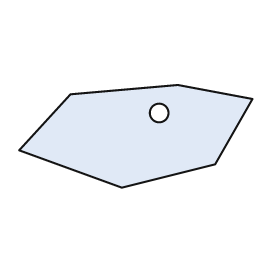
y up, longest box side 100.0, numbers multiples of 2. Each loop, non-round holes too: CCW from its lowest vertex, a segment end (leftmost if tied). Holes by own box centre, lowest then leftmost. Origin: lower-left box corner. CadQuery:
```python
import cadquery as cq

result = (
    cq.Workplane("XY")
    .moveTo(44.0, 0.0)
    .lineTo(84.0, 10.0)
    .lineTo(100.0, 38.0)
    .lineTo(68.0, 44.0)
    .lineTo(22.0, 40.0)
    .lineTo(0.0, 16.0)
    .close()
    .moveTo(60.0, 32.0)
    .circle(4.0)
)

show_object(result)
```